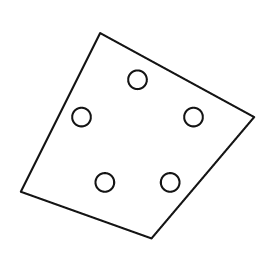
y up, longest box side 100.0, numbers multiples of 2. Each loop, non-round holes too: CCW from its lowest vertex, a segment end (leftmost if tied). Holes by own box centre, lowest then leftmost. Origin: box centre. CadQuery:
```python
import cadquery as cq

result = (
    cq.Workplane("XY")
    .moveTo(6.0, -44.0)
    .lineTo(50.0, 8.0)
    .lineTo(-16.0, 44.0)
    .lineTo(-50.0, -24.0)
    .close()
    .moveTo(-14.0, -20.0)
    .circle(4.0)
    .moveTo(14.0, -20.0)
    .circle(4.0)
    .moveTo(-24.0, 8.0)
    .circle(4.0)
    .moveTo(24.0, 8.0)
    .circle(4.0)
    .moveTo(0.0, 24.0)
    .circle(4.0)
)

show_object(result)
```